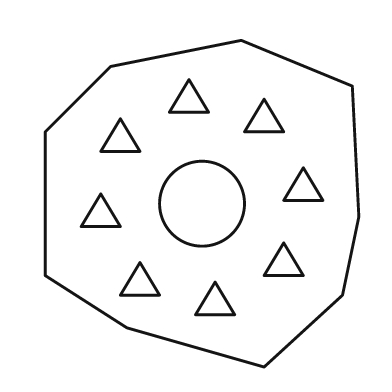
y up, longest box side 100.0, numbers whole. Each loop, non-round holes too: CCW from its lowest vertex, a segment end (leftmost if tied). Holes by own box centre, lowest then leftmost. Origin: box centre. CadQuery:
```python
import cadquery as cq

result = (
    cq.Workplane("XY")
    .moveTo(19.0, -50.0)
    .lineTo(43.0, -28.0)
    .lineTo(48.0, -4.0)
    .lineTo(46.0, 36.0)
    .lineTo(12.0, 50.0)
    .lineTo(-28.0, 42.0)
    .lineTo(-48.0, 22.0)
    .lineTo(-48.0, -22.0)
    .lineTo(-23.0, -38.0)
    .close()
    .moveTo(-2.0, -34.0)
    .lineTo(10.0, -34.0)
    .lineTo(4.0, -24.0)
    .close()
    .moveTo(-25.0, -28.0)
    .lineTo(-13.0, -28.0)
    .lineTo(-19.0, -18.0)
    .close()
    .moveTo(19.0, -22.0)
    .lineTo(31.0, -22.0)
    .lineTo(25.0, -12.0)
    .close()
    .moveTo(-37.0, -7.0)
    .lineTo(-25.0, -7.0)
    .lineTo(-31.0, 3.0)
    .close()
    .moveTo(0.0, 0.0)
    .circle(13.0)
    .moveTo(25.0, 1.0)
    .lineTo(37.0, 1.0)
    .lineTo(31.0, 11.0)
    .close()
    .moveTo(-31.0, 16.0)
    .lineTo(-19.0, 16.0)
    .lineTo(-25.0, 26.0)
    .close()
    .moveTo(13.0, 22.0)
    .lineTo(25.0, 22.0)
    .lineTo(19.0, 32.0)
    .close()
    .moveTo(-10.0, 28.0)
    .lineTo(2.0, 28.0)
    .lineTo(-4.0, 38.0)
    .close()
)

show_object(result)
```